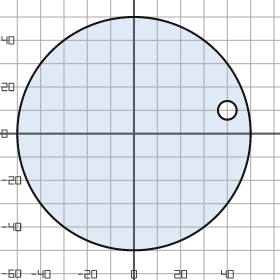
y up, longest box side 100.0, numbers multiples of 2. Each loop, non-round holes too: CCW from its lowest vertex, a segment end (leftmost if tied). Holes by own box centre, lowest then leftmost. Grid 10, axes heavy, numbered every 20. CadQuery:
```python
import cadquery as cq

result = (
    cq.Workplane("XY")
    .moveTo(0.0, 0.0)
    .circle(50.0)
    .moveTo(40.0, 10.0)
    .circle(4.0)
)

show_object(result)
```